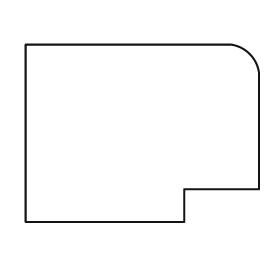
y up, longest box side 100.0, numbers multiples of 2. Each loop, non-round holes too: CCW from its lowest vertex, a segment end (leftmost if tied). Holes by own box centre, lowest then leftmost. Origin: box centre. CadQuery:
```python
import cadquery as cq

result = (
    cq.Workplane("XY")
    .moveTo(-50.0, -38.0)
    .lineTo(18.0, -38.0)
    .lineTo(18.0, -24.0)
    .lineTo(50.0, -24.0)
    .lineTo(50.0, 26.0)
    .threePointArc((46.0, 34.0), (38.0, 38.0))
    .lineTo(-50.0, 38.0)
    .close()
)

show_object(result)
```